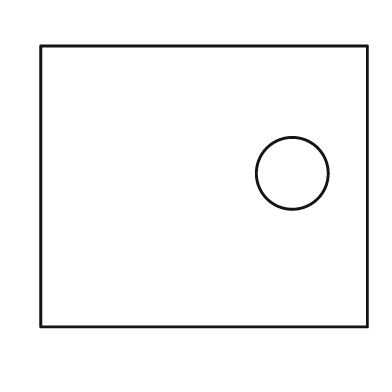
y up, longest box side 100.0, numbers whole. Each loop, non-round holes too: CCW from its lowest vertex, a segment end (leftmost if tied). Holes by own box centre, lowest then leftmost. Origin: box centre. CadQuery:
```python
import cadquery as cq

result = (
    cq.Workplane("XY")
    .moveTo(-50.0, -43.0)
    .lineTo(50.0, -43.0)
    .lineTo(50.0, 43.0)
    .lineTo(-50.0, 43.0)
    .close()
    .moveTo(27.0, 4.0)
    .circle(11.0)
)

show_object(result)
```